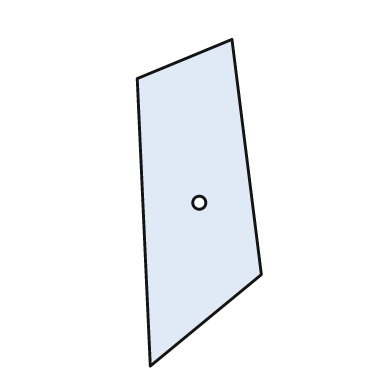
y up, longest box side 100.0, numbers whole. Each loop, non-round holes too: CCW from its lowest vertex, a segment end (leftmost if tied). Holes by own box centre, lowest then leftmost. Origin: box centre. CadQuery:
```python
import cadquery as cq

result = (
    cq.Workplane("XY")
    .moveTo(-15.0, -50.0)
    .lineTo(19.0, -22.0)
    .lineTo(10.0, 50.0)
    .lineTo(-19.0, 38.0)
    .close()
    .moveTo(0.0, 0.0)
    .circle(2.0)
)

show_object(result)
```